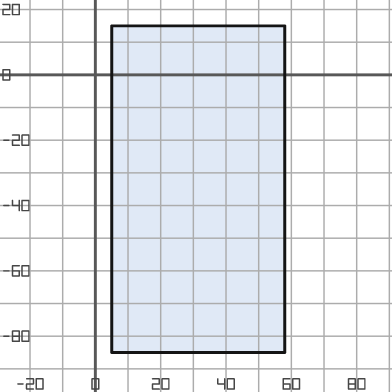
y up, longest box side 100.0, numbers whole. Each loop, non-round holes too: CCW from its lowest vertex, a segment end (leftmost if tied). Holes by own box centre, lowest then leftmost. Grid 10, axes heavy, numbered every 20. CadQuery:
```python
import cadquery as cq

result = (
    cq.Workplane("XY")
    .moveTo(5.0, -85.0)
    .lineTo(58.0, -85.0)
    .lineTo(58.0, 15.0)
    .lineTo(5.0, 15.0)
    .close()
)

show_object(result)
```